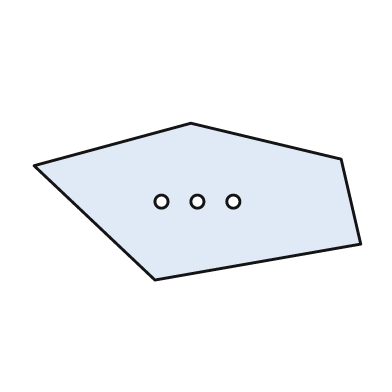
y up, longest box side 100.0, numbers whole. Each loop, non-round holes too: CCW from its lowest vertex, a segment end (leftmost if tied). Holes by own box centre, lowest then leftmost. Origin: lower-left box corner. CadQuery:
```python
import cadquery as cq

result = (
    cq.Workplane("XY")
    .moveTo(37.0, 0.0)
    .lineTo(100.0, 11.0)
    .lineTo(94.0, 37.0)
    .lineTo(48.0, 48.0)
    .lineTo(0.0, 35.0)
    .close()
    .moveTo(39.0, 24.0)
    .circle(2.0)
    .moveTo(50.0, 24.0)
    .circle(2.0)
    .moveTo(61.0, 24.0)
    .circle(2.0)
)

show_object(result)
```